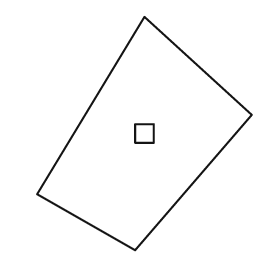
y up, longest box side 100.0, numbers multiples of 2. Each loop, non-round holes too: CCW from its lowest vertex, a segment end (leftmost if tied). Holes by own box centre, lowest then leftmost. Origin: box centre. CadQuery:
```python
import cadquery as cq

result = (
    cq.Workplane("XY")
    .moveTo(-4.0, -50.0)
    .lineTo(46.0, 8.0)
    .lineTo(0.0, 50.0)
    .lineTo(-46.0, -26.0)
    .close()
    .moveTo(-4.0, -4.0)
    .lineTo(4.0, -4.0)
    .lineTo(4.0, 4.0)
    .lineTo(-4.0, 4.0)
    .close()
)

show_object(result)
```